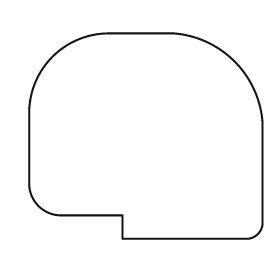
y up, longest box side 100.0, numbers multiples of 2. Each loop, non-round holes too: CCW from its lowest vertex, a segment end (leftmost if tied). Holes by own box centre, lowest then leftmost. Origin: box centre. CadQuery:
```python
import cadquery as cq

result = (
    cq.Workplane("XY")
    .moveTo(-10.0, -44.0)
    .lineTo(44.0, -44.0)
    .threePointArc((48.0, -42.0), (50.0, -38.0))
    .lineTo(50.0, 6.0)
    .threePointArc((38.0, 32.0), (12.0, 44.0))
    .lineTo(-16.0, 44.0)
    .threePointArc((-40.0, 34.0), (-50.0, 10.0))
    .lineTo(-50.0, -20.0)
    .threePointArc((-46.0, -30.0), (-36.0, -34.0))
    .lineTo(-10.0, -34.0)
    .close()
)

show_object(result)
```